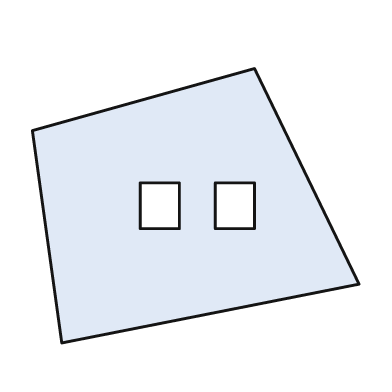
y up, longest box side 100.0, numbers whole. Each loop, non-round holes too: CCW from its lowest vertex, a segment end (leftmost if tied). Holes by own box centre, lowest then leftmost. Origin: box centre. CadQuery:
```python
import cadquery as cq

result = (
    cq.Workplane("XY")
    .moveTo(-41.0, -42.0)
    .lineTo(50.0, -24.0)
    .lineTo(18.0, 42.0)
    .lineTo(-50.0, 23.0)
    .close()
    .moveTo(-17.0, -7.0)
    .lineTo(-5.0, -7.0)
    .lineTo(-5.0, 7.0)
    .lineTo(-17.0, 7.0)
    .close()
    .moveTo(6.0, -7.0)
    .lineTo(18.0, -7.0)
    .lineTo(18.0, 7.0)
    .lineTo(6.0, 7.0)
    .close()
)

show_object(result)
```